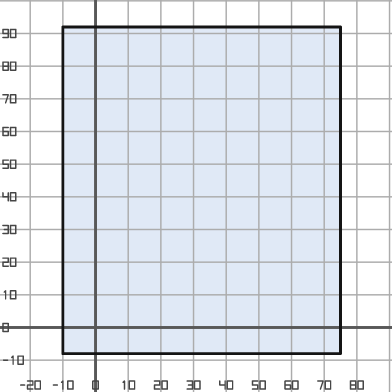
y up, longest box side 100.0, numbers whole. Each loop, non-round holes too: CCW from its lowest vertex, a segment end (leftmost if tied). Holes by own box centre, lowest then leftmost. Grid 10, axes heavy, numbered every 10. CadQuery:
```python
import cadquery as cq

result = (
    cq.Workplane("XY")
    .moveTo(-10.0, -8.0)
    .lineTo(75.0, -8.0)
    .lineTo(75.0, 92.0)
    .lineTo(-10.0, 92.0)
    .close()
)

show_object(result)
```